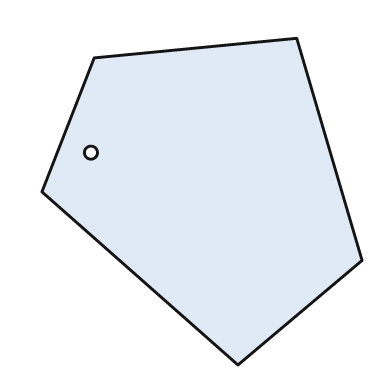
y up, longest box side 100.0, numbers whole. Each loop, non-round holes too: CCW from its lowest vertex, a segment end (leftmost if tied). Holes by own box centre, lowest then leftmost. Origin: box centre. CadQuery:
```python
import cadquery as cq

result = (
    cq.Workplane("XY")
    .moveTo(11.0, -50.0)
    .lineTo(49.0, -18.0)
    .lineTo(29.0, 50.0)
    .lineTo(-33.0, 44.0)
    .lineTo(-49.0, 3.0)
    .close()
    .moveTo(-34.0, 15.0)
    .circle(2.0)
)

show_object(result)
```